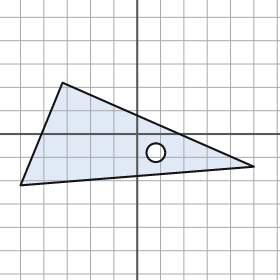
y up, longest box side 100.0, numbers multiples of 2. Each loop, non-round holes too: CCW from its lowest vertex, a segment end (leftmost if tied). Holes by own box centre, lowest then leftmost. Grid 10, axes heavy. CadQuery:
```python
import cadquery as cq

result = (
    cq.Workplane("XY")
    .moveTo(-50.0, -22.0)
    .lineTo(50.0, -14.0)
    .lineTo(-32.0, 22.0)
    .close()
    .moveTo(8.0, -8.0)
    .circle(4.0)
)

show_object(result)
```